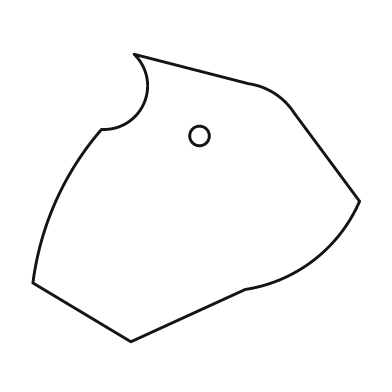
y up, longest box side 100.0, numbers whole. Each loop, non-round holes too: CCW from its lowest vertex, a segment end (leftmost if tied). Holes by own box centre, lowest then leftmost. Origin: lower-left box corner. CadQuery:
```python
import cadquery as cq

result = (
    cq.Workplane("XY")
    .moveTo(30.0, 0.0)
    .lineTo(65.0, 16.0)
    .threePointArc((86.0, 25.0), (100.0, 43.0))
    .lineTo(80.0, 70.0)
    .threePointArc((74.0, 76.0), (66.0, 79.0))
    .lineTo(31.0, 88.0)
    .threePointArc((34.0, 73.0), (21.0, 65.0))
    .threePointArc((7.0, 43.0), (0.0, 18.0))
    .close()
    .moveTo(51.0, 63.0)
    .circle(3.0)
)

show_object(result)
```